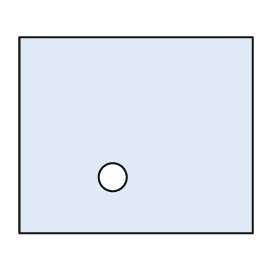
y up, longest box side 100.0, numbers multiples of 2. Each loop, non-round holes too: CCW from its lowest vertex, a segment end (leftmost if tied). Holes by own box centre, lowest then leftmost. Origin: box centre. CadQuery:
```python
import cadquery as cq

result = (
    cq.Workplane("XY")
    .moveTo(-50.0, -42.0)
    .lineTo(50.0, -42.0)
    .lineTo(50.0, 42.0)
    .lineTo(-50.0, 42.0)
    .close()
    .moveTo(-10.0, -18.0)
    .circle(6.0)
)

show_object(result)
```